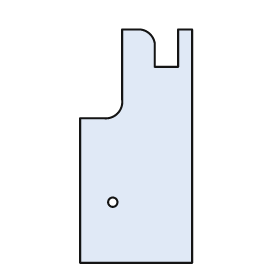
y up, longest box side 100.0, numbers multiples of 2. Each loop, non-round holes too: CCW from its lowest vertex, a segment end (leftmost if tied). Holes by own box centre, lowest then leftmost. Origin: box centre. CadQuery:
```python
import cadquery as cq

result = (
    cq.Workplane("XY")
    .moveTo(-24.0, -50.0)
    .lineTo(24.0, -50.0)
    .lineTo(24.0, 50.0)
    .lineTo(18.0, 50.0)
    .lineTo(18.0, 34.0)
    .lineTo(8.0, 34.0)
    .lineTo(8.0, 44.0)
    .threePointArc((6.0, 48.0), (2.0, 50.0))
    .lineTo(-6.0, 50.0)
    .lineTo(-6.0, 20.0)
    .threePointArc((-8.0, 14.0), (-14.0, 12.0))
    .lineTo(-24.0, 12.0)
    .close()
    .moveTo(-10.0, -24.0)
    .circle(2.0)
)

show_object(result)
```